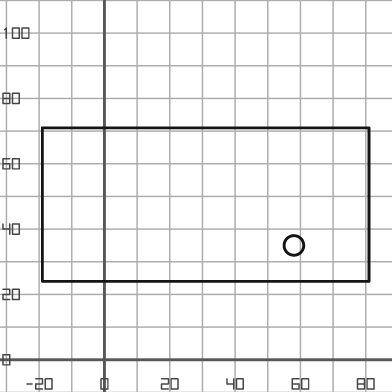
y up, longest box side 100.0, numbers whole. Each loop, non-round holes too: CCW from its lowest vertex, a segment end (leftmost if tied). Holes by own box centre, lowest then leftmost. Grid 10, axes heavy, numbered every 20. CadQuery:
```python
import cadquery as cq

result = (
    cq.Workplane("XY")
    .moveTo(-19.0, 24.0)
    .lineTo(81.0, 24.0)
    .lineTo(81.0, 71.0)
    .lineTo(-19.0, 71.0)
    .close()
    .moveTo(58.0, 35.0)
    .circle(3.0)
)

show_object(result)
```